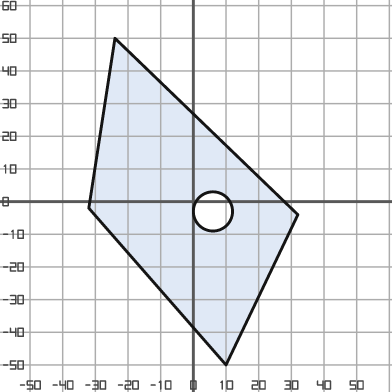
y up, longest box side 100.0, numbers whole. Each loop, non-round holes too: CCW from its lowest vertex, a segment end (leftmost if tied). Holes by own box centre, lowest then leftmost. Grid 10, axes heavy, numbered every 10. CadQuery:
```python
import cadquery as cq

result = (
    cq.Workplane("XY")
    .moveTo(10.0, -50.0)
    .lineTo(32.0, -4.0)
    .lineTo(-24.0, 50.0)
    .lineTo(-32.0, -2.0)
    .close()
    .moveTo(6.0, -3.0)
    .circle(6.0)
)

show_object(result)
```